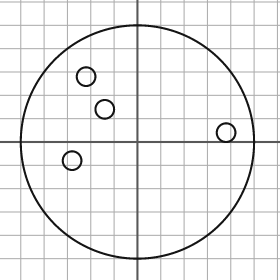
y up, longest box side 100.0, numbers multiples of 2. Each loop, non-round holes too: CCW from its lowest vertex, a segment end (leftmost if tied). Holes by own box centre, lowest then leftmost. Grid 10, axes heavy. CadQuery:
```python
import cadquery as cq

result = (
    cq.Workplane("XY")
    .moveTo(0.0, 0.0)
    .circle(50.0)
    .moveTo(-28.0, -8.0)
    .circle(4.0)
    .moveTo(38.0, 4.0)
    .circle(4.0)
    .moveTo(-14.0, 14.0)
    .circle(4.0)
    .moveTo(-22.0, 28.0)
    .circle(4.0)
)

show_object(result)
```